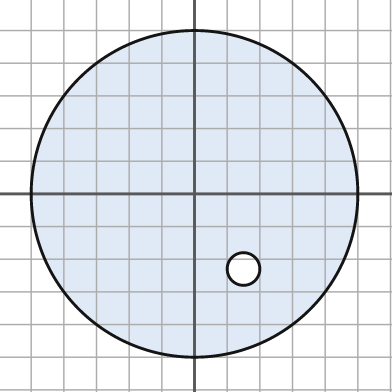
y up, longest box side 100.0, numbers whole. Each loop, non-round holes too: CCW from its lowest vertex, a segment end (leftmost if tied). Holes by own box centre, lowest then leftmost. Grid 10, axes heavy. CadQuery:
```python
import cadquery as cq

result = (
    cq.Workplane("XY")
    .moveTo(0.0, 0.0)
    .circle(50.0)
    .moveTo(15.0, -23.0)
    .circle(5.0)
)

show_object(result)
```